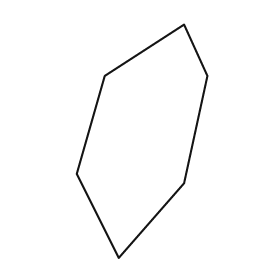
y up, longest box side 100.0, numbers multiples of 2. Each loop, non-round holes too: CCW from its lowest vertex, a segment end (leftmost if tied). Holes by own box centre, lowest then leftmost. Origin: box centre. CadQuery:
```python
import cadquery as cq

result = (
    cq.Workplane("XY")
    .moveTo(-10.0, -50.0)
    .lineTo(18.0, -18.0)
    .lineTo(28.0, 28.0)
    .lineTo(18.0, 50.0)
    .lineTo(-16.0, 28.0)
    .lineTo(-28.0, -14.0)
    .close()
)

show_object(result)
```